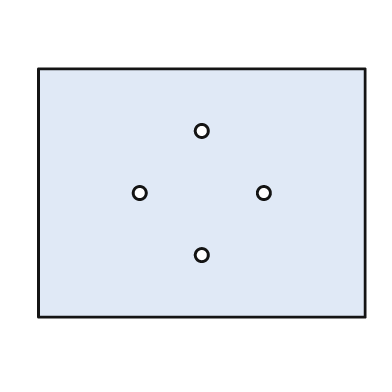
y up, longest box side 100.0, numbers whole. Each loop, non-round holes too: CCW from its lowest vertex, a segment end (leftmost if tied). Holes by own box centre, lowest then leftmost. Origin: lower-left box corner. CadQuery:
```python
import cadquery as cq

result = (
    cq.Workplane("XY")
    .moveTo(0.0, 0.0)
    .lineTo(100.0, 0.0)
    .lineTo(100.0, 76.0)
    .lineTo(0.0, 76.0)
    .close()
    .moveTo(50.0, 19.0)
    .circle(2.0)
    .moveTo(31.0, 38.0)
    .circle(2.0)
    .moveTo(69.0, 38.0)
    .circle(2.0)
    .moveTo(50.0, 57.0)
    .circle(2.0)
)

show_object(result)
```